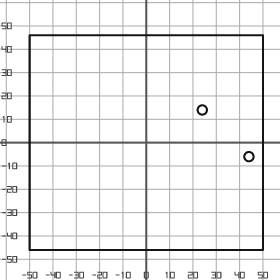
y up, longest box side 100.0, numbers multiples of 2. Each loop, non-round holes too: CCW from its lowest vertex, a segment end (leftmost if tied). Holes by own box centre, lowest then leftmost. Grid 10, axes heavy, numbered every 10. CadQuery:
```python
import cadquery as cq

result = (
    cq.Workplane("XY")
    .moveTo(-50.0, -46.0)
    .lineTo(50.0, -46.0)
    .lineTo(50.0, 46.0)
    .lineTo(-50.0, 46.0)
    .close()
    .moveTo(44.0, -6.0)
    .circle(2.0)
    .moveTo(24.0, 14.0)
    .circle(2.0)
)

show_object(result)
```